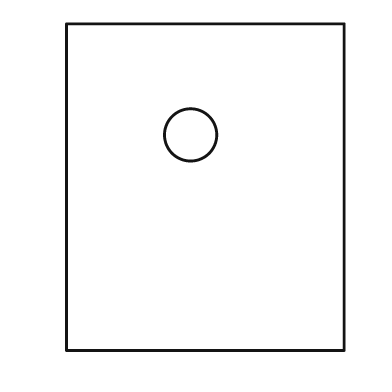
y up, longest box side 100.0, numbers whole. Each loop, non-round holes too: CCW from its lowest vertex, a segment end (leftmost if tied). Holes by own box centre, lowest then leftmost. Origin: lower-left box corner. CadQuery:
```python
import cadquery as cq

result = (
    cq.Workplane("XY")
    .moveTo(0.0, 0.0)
    .lineTo(85.0, 0.0)
    .lineTo(85.0, 100.0)
    .lineTo(0.0, 100.0)
    .close()
    .moveTo(38.0, 66.0)
    .circle(8.0)
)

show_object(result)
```